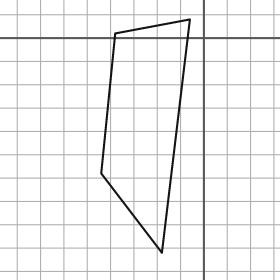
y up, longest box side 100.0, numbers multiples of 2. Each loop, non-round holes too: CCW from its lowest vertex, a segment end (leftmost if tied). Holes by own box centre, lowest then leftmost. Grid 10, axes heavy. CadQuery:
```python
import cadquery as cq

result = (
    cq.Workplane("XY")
    .moveTo(-18.0, -92.0)
    .lineTo(-6.0, 8.0)
    .lineTo(-38.0, 2.0)
    .lineTo(-44.0, -58.0)
    .close()
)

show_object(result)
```